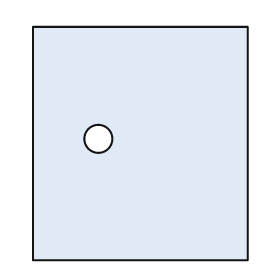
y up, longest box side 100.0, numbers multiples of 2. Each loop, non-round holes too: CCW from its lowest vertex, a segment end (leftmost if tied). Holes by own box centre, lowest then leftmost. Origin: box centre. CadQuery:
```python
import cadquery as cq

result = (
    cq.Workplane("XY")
    .moveTo(-46.0, -50.0)
    .lineTo(46.0, -50.0)
    .lineTo(46.0, 50.0)
    .lineTo(-46.0, 50.0)
    .close()
    .moveTo(-18.0, 2.0)
    .circle(6.0)
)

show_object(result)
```